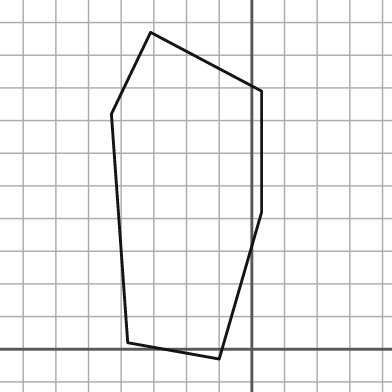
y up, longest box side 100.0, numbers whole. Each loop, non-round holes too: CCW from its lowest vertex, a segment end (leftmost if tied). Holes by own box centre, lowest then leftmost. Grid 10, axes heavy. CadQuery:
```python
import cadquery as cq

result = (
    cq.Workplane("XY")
    .moveTo(-10.0, -3.0)
    .lineTo(3.0, 42.0)
    .lineTo(3.0, 79.0)
    .lineTo(-31.0, 97.0)
    .lineTo(-43.0, 72.0)
    .lineTo(-38.0, 2.0)
    .close()
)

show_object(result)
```